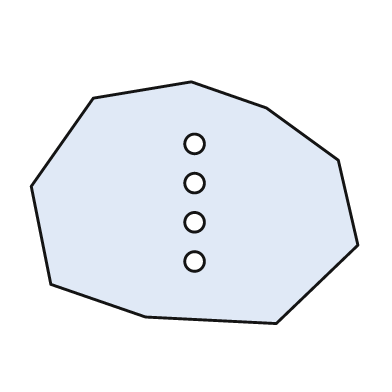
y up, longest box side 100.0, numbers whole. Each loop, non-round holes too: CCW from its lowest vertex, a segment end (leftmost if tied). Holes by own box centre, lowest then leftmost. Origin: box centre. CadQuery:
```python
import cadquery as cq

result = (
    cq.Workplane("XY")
    .moveTo(25.0, -37.0)
    .lineTo(50.0, -13.0)
    .lineTo(44.0, 13.0)
    .lineTo(22.0, 29.0)
    .lineTo(-1.0, 37.0)
    .lineTo(-31.0, 32.0)
    .lineTo(-50.0, 5.0)
    .lineTo(-44.0, -25.0)
    .lineTo(-15.0, -35.0)
    .close()
    .moveTo(0.0, -18.0)
    .circle(3.0)
    .moveTo(0.0, -6.0)
    .circle(3.0)
    .moveTo(0.0, 6.0)
    .circle(3.0)
    .moveTo(0.0, 18.0)
    .circle(3.0)
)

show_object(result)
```